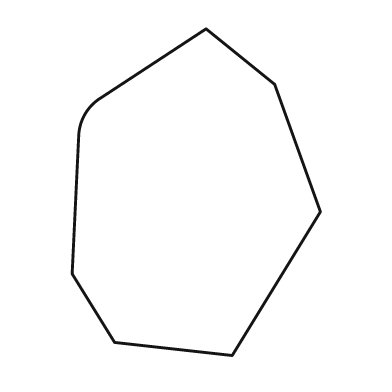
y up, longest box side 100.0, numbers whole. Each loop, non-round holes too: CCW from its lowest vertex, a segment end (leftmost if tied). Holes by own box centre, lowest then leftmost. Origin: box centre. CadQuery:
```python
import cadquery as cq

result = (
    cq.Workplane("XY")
    .moveTo(11.0, -50.0)
    .lineTo(38.0, -6.0)
    .lineTo(24.0, 33.0)
    .lineTo(3.0, 50.0)
    .lineTo(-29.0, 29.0)
    .threePointArc((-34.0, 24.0), (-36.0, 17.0))
    .lineTo(-38.0, -25.0)
    .lineTo(-25.0, -46.0)
    .close()
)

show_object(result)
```